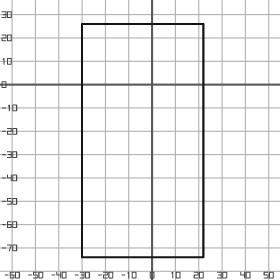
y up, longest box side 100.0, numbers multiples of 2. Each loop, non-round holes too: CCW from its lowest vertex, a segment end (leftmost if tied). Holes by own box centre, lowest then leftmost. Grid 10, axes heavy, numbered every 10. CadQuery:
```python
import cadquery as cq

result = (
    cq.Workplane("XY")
    .moveTo(-30.0, -74.0)
    .lineTo(22.0, -74.0)
    .lineTo(22.0, 26.0)
    .lineTo(-30.0, 26.0)
    .close()
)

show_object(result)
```